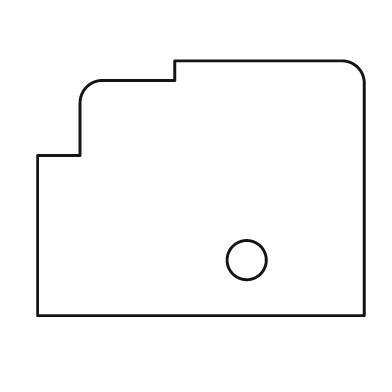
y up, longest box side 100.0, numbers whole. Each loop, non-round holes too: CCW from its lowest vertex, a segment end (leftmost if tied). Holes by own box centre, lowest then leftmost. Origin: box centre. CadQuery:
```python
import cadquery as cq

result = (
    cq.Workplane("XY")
    .moveTo(-50.0, -39.0)
    .lineTo(50.0, -39.0)
    .lineTo(50.0, 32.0)
    .threePointArc((48.0, 37.0), (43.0, 39.0))
    .lineTo(-8.0, 39.0)
    .lineTo(-8.0, 33.0)
    .lineTo(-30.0, 33.0)
    .threePointArc((-35.0, 31.0), (-37.0, 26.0))
    .lineTo(-37.0, 10.0)
    .lineTo(-50.0, 10.0)
    .close()
    .moveTo(14.0, -22.0)
    .circle(6.0)
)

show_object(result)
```